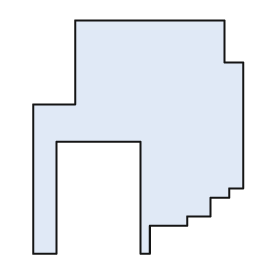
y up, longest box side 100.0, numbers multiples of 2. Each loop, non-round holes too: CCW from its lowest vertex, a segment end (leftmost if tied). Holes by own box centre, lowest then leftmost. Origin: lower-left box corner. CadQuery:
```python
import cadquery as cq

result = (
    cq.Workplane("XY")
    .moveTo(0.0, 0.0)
    .lineTo(10.0, 0.0)
    .lineTo(10.0, 48.0)
    .lineTo(46.0, 48.0)
    .lineTo(46.0, 0.0)
    .lineTo(50.0, 0.0)
    .lineTo(50.0, 12.0)
    .lineTo(66.0, 12.0)
    .lineTo(66.0, 16.0)
    .lineTo(76.0, 16.0)
    .lineTo(76.0, 24.0)
    .lineTo(84.0, 24.0)
    .lineTo(84.0, 28.0)
    .lineTo(90.0, 28.0)
    .lineTo(90.0, 82.0)
    .lineTo(82.0, 82.0)
    .lineTo(82.0, 100.0)
    .lineTo(18.0, 100.0)
    .lineTo(18.0, 64.0)
    .lineTo(0.0, 64.0)
    .close()
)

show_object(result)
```